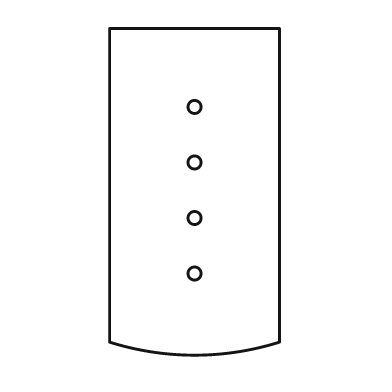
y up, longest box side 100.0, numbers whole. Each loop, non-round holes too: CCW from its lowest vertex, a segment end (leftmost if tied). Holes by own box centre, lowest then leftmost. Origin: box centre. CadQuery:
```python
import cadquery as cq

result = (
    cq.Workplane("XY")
    .moveTo(-26.0, -46.0)
    .threePointArc((0.0, -50.0), (26.0, -46.0))
    .lineTo(26.0, 50.0)
    .lineTo(-26.0, 50.0)
    .close()
    .moveTo(0.0, -25.0)
    .circle(2.0)
    .moveTo(0.0, -8.0)
    .circle(2.0)
    .moveTo(0.0, 9.0)
    .circle(2.0)
    .moveTo(0.0, 26.0)
    .circle(2.0)
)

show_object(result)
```